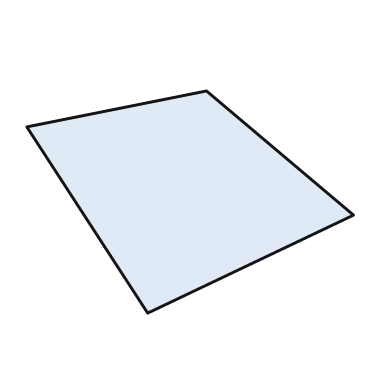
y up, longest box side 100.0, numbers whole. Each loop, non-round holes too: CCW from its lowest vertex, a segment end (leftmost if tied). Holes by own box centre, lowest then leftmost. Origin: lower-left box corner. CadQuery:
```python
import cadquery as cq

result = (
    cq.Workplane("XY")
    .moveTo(37.0, 0.0)
    .lineTo(100.0, 30.0)
    .lineTo(55.0, 68.0)
    .lineTo(0.0, 57.0)
    .close()
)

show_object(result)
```